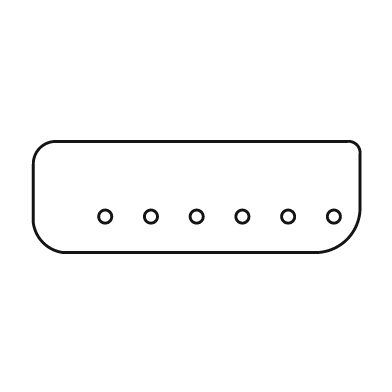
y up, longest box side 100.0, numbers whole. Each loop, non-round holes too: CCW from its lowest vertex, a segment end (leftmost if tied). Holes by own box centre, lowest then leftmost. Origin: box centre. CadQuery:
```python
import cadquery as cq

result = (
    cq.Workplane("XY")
    .moveTo(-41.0, -17.0)
    .lineTo(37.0, -17.0)
    .threePointArc((46.0, -13.0), (50.0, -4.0))
    .lineTo(50.0, 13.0)
    .threePointArc((49.0, 16.0), (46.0, 17.0))
    .lineTo(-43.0, 17.0)
    .threePointArc((-48.0, 15.0), (-50.0, 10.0))
    .lineTo(-50.0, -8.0)
    .threePointArc((-47.0, -14.0), (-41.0, -17.0))
    .close()
    .moveTo(-28.0, -6.0)
    .circle(2.0)
    .moveTo(-14.0, -6.0)
    .circle(2.0)
    .moveTo(0.0, -6.0)
    .circle(2.0)
    .moveTo(14.0, -6.0)
    .circle(2.0)
    .moveTo(28.0, -6.0)
    .circle(2.0)
    .moveTo(42.0, -6.0)
    .circle(2.0)
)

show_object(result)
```